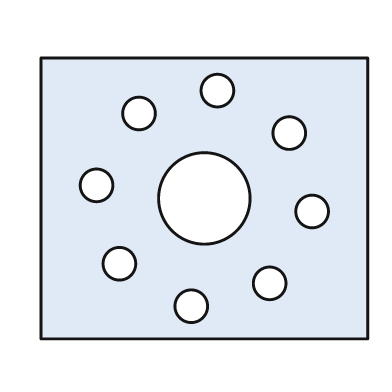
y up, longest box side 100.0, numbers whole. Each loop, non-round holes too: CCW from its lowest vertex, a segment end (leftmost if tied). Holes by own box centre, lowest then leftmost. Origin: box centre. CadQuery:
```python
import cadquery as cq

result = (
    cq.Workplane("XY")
    .moveTo(-50.0, -43.0)
    .lineTo(50.0, -43.0)
    .lineTo(50.0, 43.0)
    .lineTo(-50.0, 43.0)
    .close()
    .moveTo(-4.0, -33.0)
    .circle(5.0)
    .moveTo(20.0, -26.0)
    .circle(5.0)
    .moveTo(-26.0, -20.0)
    .circle(5.0)
    .moveTo(33.0, -4.0)
    .circle(5.0)
    .moveTo(0.0, 0.0)
    .circle(14.0)
    .moveTo(-33.0, 4.0)
    .circle(5.0)
    .moveTo(26.0, 20.0)
    .circle(5.0)
    .moveTo(-20.0, 26.0)
    .circle(5.0)
    .moveTo(4.0, 33.0)
    .circle(5.0)
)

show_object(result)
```